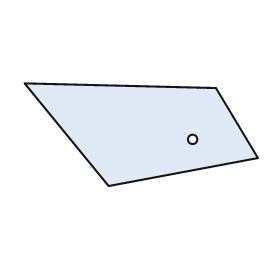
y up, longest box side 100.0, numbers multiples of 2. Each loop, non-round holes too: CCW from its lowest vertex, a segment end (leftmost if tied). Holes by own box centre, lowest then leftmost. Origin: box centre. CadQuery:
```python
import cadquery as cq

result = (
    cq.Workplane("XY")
    .moveTo(-14.0, -22.0)
    .lineTo(50.0, -10.0)
    .lineTo(32.0, 20.0)
    .lineTo(-50.0, 22.0)
    .close()
    .moveTo(22.0, -2.0)
    .circle(2.0)
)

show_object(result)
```